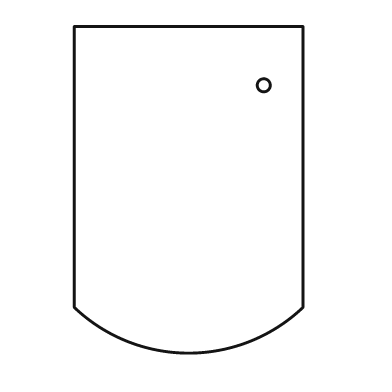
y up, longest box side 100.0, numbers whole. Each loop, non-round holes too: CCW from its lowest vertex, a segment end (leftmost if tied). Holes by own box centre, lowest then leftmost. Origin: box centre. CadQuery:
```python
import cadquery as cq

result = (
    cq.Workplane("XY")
    .moveTo(-35.0, -36.0)
    .threePointArc((0.0, -50.0), (35.0, -36.0))
    .lineTo(35.0, 50.0)
    .lineTo(-35.0, 50.0)
    .close()
    .moveTo(23.0, 32.0)
    .circle(2.0)
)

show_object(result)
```